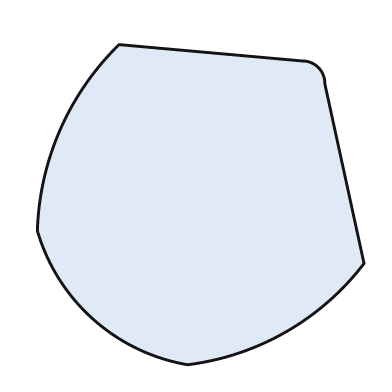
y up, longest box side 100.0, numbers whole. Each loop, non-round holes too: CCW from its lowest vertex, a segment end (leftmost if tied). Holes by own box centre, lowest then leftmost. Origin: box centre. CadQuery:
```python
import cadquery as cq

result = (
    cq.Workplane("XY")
    .moveTo(-4.0, -49.0)
    .threePointArc((26.0, -39.0), (50.0, -18.0))
    .lineTo(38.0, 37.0)
    .threePointArc((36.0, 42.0), (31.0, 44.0))
    .lineTo(-25.0, 49.0)
    .threePointArc((-43.0, 23.0), (-50.0, -8.0))
    .threePointArc((-33.0, -35.0), (-4.0, -49.0))
    .close()
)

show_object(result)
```